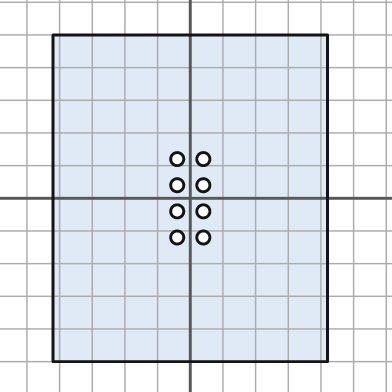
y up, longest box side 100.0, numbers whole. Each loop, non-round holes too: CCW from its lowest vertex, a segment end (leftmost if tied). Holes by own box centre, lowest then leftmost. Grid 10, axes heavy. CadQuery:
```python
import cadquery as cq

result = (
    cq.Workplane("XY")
    .moveTo(-42.0, -50.0)
    .lineTo(42.0, -50.0)
    .lineTo(42.0, 50.0)
    .lineTo(-42.0, 50.0)
    .close()
    .moveTo(-4.0, -12.0)
    .circle(2.0)
    .moveTo(4.0, -12.0)
    .circle(2.0)
    .moveTo(-4.0, -4.0)
    .circle(2.0)
    .moveTo(4.0, -4.0)
    .circle(2.0)
    .moveTo(-4.0, 4.0)
    .circle(2.0)
    .moveTo(4.0, 4.0)
    .circle(2.0)
    .moveTo(-4.0, 12.0)
    .circle(2.0)
    .moveTo(4.0, 12.0)
    .circle(2.0)
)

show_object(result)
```